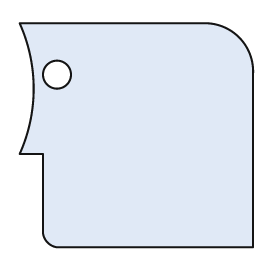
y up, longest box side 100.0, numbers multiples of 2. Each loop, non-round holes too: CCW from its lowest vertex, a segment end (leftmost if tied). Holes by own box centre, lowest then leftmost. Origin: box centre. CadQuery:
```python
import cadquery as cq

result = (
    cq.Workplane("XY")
    .moveTo(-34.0, -48.0)
    .lineTo(50.0, -48.0)
    .lineTo(50.0, 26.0)
    .threePointArc((44.0, 42.0), (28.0, 48.0))
    .lineTo(-50.0, 48.0)
    .threePointArc((-44.0, 20.0), (-50.0, -8.0))
    .lineTo(-40.0, -8.0)
    .lineTo(-40.0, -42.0)
    .threePointArc((-38.0, -46.0), (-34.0, -48.0))
    .close()
    .moveTo(-34.0, 26.0)
    .circle(6.0)
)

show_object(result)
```